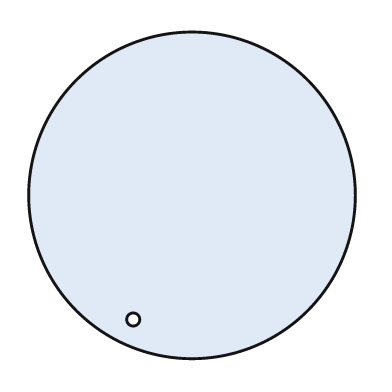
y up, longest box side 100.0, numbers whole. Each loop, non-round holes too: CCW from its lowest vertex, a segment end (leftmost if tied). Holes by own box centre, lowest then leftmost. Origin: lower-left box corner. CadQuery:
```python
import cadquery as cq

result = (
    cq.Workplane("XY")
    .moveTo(50.0, 50.0)
    .circle(50.0)
    .moveTo(32.0, 12.0)
    .circle(2.0)
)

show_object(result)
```